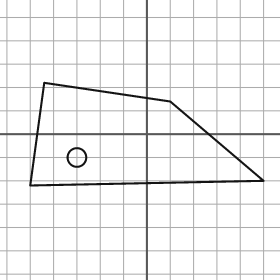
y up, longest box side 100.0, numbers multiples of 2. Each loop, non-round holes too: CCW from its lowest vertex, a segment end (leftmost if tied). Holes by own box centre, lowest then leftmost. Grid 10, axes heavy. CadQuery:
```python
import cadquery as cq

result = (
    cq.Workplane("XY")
    .moveTo(-50.0, -22.0)
    .lineTo(50.0, -20.0)
    .lineTo(10.0, 14.0)
    .lineTo(-44.0, 22.0)
    .close()
    .moveTo(-30.0, -10.0)
    .circle(4.0)
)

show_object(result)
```